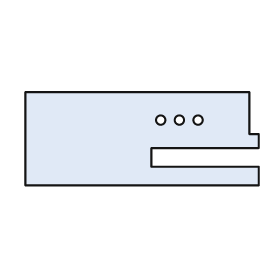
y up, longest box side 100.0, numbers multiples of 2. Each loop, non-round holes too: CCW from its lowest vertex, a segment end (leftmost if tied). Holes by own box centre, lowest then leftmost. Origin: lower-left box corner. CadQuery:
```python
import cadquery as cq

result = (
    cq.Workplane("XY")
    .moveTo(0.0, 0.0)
    .lineTo(100.0, 0.0)
    .lineTo(100.0, 8.0)
    .lineTo(54.0, 8.0)
    .lineTo(54.0, 16.0)
    .lineTo(100.0, 16.0)
    .lineTo(100.0, 22.0)
    .lineTo(96.0, 22.0)
    .lineTo(96.0, 40.0)
    .lineTo(0.0, 40.0)
    .close()
    .moveTo(58.0, 28.0)
    .circle(2.0)
    .moveTo(66.0, 28.0)
    .circle(2.0)
    .moveTo(74.0, 28.0)
    .circle(2.0)
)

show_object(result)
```